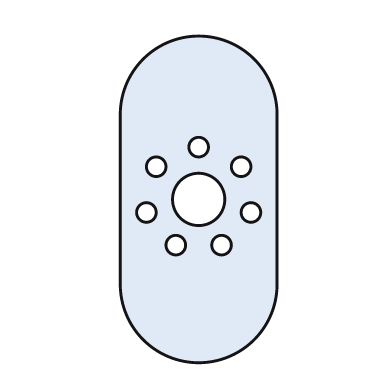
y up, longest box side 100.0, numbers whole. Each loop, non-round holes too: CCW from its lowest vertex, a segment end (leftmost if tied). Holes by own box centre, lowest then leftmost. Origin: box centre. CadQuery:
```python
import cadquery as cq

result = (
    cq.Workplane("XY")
    .moveTo(-24.0, -26.0)
    .threePointArc((0.0, -50.0), (24.0, -26.0))
    .lineTo(24.0, 26.0)
    .threePointArc((0.0, 50.0), (-24.0, 26.0))
    .close()
    .moveTo(-7.0, -14.0)
    .circle(3.0)
    .moveTo(7.0, -14.0)
    .circle(3.0)
    .moveTo(-16.0, -4.0)
    .circle(3.0)
    .moveTo(16.0, -4.0)
    .circle(3.0)
    .moveTo(0.0, 0.0)
    .circle(8.0)
    .moveTo(-13.0, 10.0)
    .circle(3.0)
    .moveTo(13.0, 10.0)
    .circle(3.0)
    .moveTo(0.0, 16.0)
    .circle(3.0)
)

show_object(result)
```